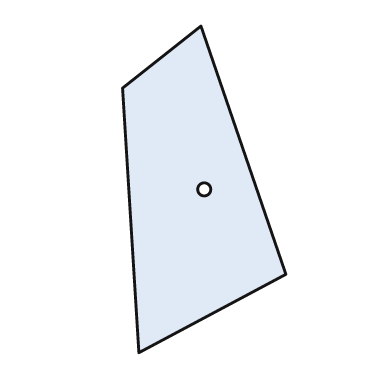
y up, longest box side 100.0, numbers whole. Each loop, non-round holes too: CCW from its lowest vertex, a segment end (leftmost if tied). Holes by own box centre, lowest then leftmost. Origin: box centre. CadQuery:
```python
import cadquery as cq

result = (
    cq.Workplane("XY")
    .moveTo(-20.0, -50.0)
    .lineTo(25.0, -26.0)
    .lineTo(-1.0, 50.0)
    .lineTo(-25.0, 31.0)
    .close()
    .moveTo(0.0, 0.0)
    .circle(2.0)
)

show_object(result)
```